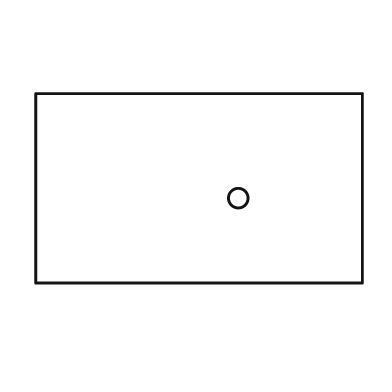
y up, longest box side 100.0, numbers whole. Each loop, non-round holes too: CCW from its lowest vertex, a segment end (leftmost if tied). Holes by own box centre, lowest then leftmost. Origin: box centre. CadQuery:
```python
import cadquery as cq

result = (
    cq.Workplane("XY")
    .moveTo(-50.0, -29.0)
    .lineTo(50.0, -29.0)
    .lineTo(50.0, 29.0)
    .lineTo(-50.0, 29.0)
    .close()
    .moveTo(12.0, -3.0)
    .circle(3.0)
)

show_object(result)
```